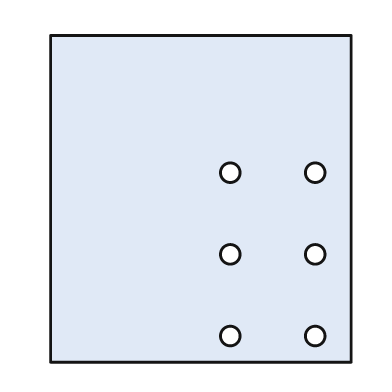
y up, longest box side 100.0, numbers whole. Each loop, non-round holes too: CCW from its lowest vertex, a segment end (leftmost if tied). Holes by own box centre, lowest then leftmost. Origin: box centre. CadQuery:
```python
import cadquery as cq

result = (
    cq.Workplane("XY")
    .moveTo(-46.0, -50.0)
    .lineTo(46.0, -50.0)
    .lineTo(46.0, 50.0)
    .lineTo(-46.0, 50.0)
    .close()
    .moveTo(9.0, -42.0)
    .circle(3.0)
    .moveTo(35.0, -42.0)
    .circle(3.0)
    .moveTo(9.0, -17.0)
    .circle(3.0)
    .moveTo(35.0, -17.0)
    .circle(3.0)
    .moveTo(9.0, 8.0)
    .circle(3.0)
    .moveTo(35.0, 8.0)
    .circle(3.0)
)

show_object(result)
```